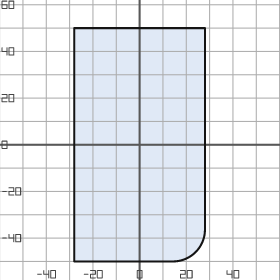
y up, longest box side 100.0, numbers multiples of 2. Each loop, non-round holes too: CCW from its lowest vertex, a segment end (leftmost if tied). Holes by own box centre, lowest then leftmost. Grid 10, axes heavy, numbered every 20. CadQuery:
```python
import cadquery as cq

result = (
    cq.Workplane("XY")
    .moveTo(-28.0, -50.0)
    .lineTo(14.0, -50.0)
    .threePointArc((24.0, -46.0), (28.0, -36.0))
    .lineTo(28.0, 50.0)
    .lineTo(-28.0, 50.0)
    .close()
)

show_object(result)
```